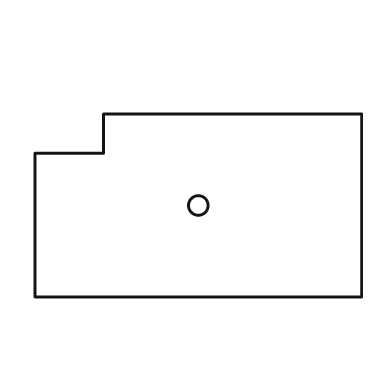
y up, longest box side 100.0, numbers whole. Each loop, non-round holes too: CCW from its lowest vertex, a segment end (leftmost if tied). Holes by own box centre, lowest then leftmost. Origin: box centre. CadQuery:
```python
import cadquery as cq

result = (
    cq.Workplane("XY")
    .moveTo(-50.0, -28.0)
    .lineTo(50.0, -28.0)
    .lineTo(50.0, 28.0)
    .lineTo(-29.0, 28.0)
    .lineTo(-29.0, 16.0)
    .lineTo(-50.0, 16.0)
    .close()
    .moveTo(0.0, 0.0)
    .circle(3.0)
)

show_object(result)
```